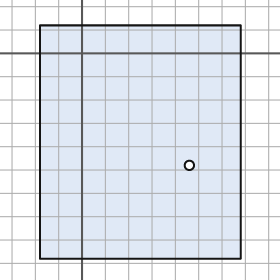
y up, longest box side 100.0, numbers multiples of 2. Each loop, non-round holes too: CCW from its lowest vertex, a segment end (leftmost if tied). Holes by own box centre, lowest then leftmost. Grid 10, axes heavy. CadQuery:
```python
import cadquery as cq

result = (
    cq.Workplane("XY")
    .moveTo(-18.0, -88.0)
    .lineTo(68.0, -88.0)
    .lineTo(68.0, 12.0)
    .lineTo(-18.0, 12.0)
    .close()
    .moveTo(46.0, -48.0)
    .circle(2.0)
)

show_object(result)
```